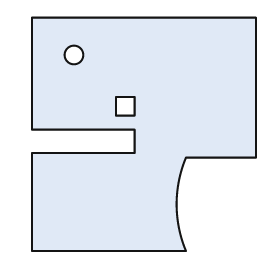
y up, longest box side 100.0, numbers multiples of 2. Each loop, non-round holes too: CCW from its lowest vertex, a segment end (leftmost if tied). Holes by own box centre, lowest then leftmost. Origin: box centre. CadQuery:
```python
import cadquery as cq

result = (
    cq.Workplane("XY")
    .moveTo(-48.0, -50.0)
    .lineTo(18.0, -50.0)
    .threePointArc((14.0, -30.0), (18.0, -10.0))
    .lineTo(48.0, -10.0)
    .lineTo(48.0, 50.0)
    .lineTo(-48.0, 50.0)
    .lineTo(-48.0, 2.0)
    .lineTo(-4.0, 2.0)
    .lineTo(-4.0, -8.0)
    .lineTo(-48.0, -8.0)
    .close()
    .moveTo(-12.0, 8.0)
    .lineTo(-4.0, 8.0)
    .lineTo(-4.0, 16.0)
    .lineTo(-12.0, 16.0)
    .close()
    .moveTo(-30.0, 34.0)
    .circle(4.0)
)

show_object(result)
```